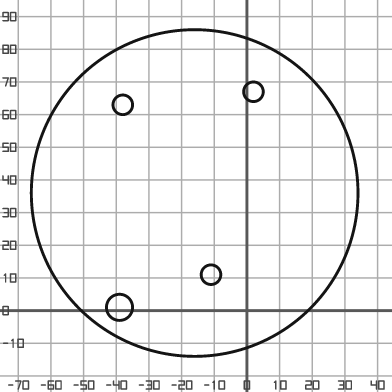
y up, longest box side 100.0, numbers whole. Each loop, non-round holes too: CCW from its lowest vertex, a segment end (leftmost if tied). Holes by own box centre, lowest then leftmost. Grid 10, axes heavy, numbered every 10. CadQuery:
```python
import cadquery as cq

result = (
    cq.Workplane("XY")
    .moveTo(-16.0, 36.0)
    .circle(50.0)
    .moveTo(-39.0, 1.0)
    .circle(4.0)
    .moveTo(-11.0, 11.0)
    .circle(3.0)
    .moveTo(-38.0, 63.0)
    .circle(3.0)
    .moveTo(2.0, 67.0)
    .circle(3.0)
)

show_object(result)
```